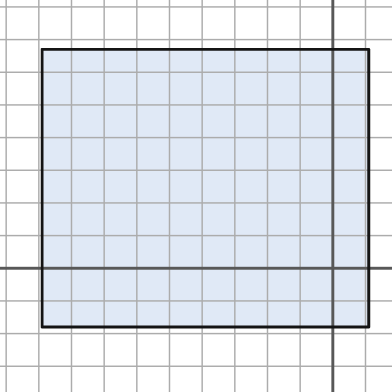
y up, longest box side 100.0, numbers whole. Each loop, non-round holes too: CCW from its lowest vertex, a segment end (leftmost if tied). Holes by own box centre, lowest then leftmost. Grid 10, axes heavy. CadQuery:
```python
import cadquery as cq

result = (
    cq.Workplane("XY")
    .moveTo(-89.0, -18.0)
    .lineTo(11.0, -18.0)
    .lineTo(11.0, 67.0)
    .lineTo(-89.0, 67.0)
    .close()
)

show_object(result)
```